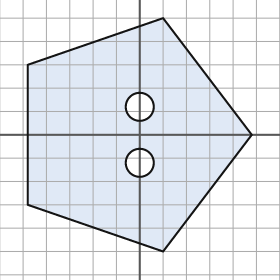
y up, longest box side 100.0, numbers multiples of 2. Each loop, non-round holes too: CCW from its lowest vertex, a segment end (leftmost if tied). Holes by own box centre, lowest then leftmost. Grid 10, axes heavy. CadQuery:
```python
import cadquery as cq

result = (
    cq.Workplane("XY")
    .moveTo(10.0, -50.0)
    .lineTo(48.0, 0.0)
    .lineTo(10.0, 50.0)
    .lineTo(-48.0, 30.0)
    .lineTo(-48.0, -30.0)
    .close()
    .moveTo(0.0, -12.0)
    .circle(6.0)
    .moveTo(0.0, 12.0)
    .circle(6.0)
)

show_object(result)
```